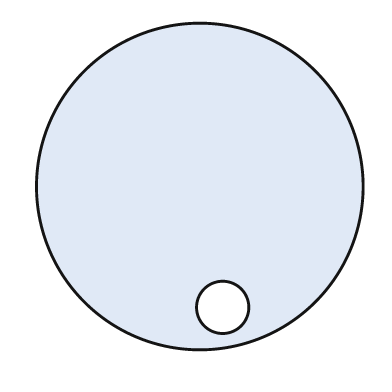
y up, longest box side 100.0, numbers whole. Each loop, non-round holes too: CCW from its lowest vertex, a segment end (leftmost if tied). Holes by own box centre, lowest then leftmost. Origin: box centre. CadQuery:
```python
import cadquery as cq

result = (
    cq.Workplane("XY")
    .moveTo(0.0, 0.0)
    .circle(50.0)
    .moveTo(7.0, -37.0)
    .circle(8.0)
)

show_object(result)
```